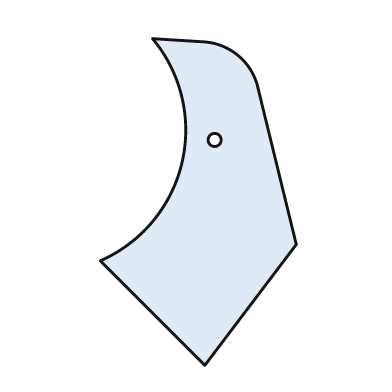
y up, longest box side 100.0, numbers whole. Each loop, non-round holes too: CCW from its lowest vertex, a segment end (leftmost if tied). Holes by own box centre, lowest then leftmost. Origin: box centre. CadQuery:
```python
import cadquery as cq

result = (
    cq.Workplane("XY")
    .moveTo(2.0, -50.0)
    .lineTo(30.0, -13.0)
    .lineTo(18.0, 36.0)
    .threePointArc((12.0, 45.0), (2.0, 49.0))
    .lineTo(-14.0, 50.0)
    .threePointArc((-5.0, 12.0), (-30.0, -18.0))
    .close()
    .moveTo(5.0, 19.0)
    .circle(2.0)
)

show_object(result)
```